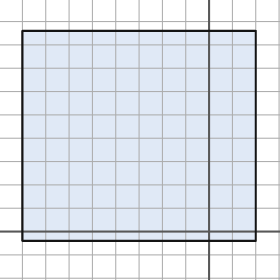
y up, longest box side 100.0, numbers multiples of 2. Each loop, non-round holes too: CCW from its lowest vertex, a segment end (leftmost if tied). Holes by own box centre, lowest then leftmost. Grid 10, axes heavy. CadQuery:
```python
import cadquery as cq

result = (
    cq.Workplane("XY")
    .moveTo(-80.0, -4.0)
    .lineTo(20.0, -4.0)
    .lineTo(20.0, 86.0)
    .lineTo(-80.0, 86.0)
    .close()
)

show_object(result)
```